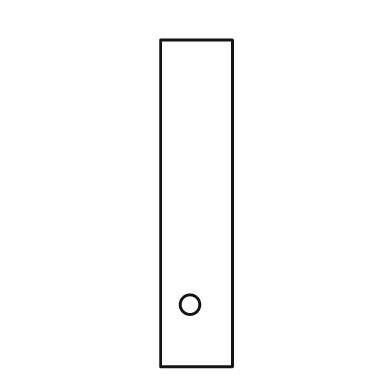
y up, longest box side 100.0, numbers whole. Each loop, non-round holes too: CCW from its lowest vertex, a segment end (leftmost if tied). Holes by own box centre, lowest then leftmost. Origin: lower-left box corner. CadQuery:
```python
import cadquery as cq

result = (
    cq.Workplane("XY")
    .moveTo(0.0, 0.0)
    .lineTo(22.0, 0.0)
    .lineTo(22.0, 100.0)
    .lineTo(0.0, 100.0)
    .close()
    .moveTo(9.0, 19.0)
    .circle(3.0)
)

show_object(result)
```